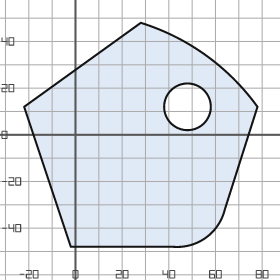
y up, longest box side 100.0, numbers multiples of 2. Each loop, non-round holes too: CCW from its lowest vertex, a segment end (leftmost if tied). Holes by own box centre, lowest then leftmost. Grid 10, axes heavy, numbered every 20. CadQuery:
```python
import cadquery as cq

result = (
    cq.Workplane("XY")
    .moveTo(-2.0, -48.0)
    .lineTo(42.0, -48.0)
    .threePointArc((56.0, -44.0), (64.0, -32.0))
    .lineTo(78.0, 12.0)
    .threePointArc((56.0, 34.0), (28.0, 48.0))
    .lineTo(-22.0, 12.0)
    .close()
    .moveTo(48.0, 12.0)
    .circle(10.0)
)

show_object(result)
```